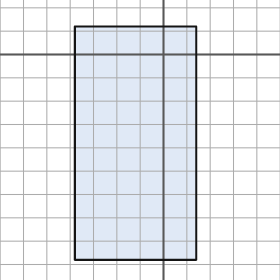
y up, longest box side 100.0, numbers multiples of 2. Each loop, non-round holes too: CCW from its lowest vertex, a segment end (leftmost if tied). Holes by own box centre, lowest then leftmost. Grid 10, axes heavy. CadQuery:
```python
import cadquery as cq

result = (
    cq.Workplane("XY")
    .moveTo(-38.0, -88.0)
    .lineTo(14.0, -88.0)
    .lineTo(14.0, 12.0)
    .lineTo(-38.0, 12.0)
    .close()
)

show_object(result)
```